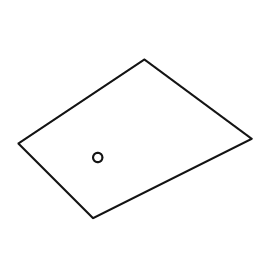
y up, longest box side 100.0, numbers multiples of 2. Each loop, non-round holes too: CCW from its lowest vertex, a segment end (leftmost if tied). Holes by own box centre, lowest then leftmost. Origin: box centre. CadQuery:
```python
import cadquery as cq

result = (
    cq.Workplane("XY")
    .moveTo(-18.0, -34.0)
    .lineTo(50.0, 0.0)
    .lineTo(4.0, 34.0)
    .lineTo(-50.0, -2.0)
    .close()
    .moveTo(-16.0, -8.0)
    .circle(2.0)
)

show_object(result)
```